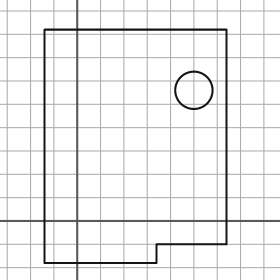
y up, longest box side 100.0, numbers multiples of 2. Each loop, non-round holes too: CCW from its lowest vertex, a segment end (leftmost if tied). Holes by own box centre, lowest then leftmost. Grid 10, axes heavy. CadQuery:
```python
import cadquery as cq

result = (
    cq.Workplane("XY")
    .moveTo(-14.0, -18.0)
    .lineTo(34.0, -18.0)
    .lineTo(34.0, -10.0)
    .lineTo(64.0, -10.0)
    .lineTo(64.0, 82.0)
    .lineTo(-14.0, 82.0)
    .close()
    .moveTo(50.0, 56.0)
    .circle(8.0)
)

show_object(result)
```